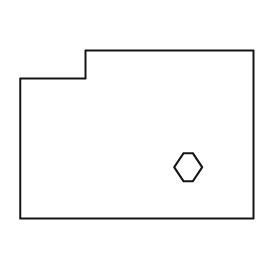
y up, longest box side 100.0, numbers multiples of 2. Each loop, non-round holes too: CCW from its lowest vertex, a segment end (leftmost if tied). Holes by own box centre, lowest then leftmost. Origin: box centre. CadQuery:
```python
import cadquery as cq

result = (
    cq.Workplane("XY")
    .moveTo(-50.0, -36.0)
    .lineTo(50.0, -36.0)
    .lineTo(50.0, 36.0)
    .lineTo(-22.0, 36.0)
    .lineTo(-22.0, 24.0)
    .lineTo(-50.0, 24.0)
    .close()
    .moveTo(20.0, -20.0)
    .lineTo(24.0, -20.0)
    .lineTo(28.0, -14.0)
    .lineTo(24.0, -8.0)
    .lineTo(20.0, -8.0)
    .lineTo(16.0, -14.0)
    .close()
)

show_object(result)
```